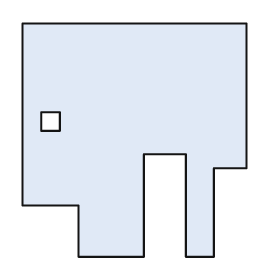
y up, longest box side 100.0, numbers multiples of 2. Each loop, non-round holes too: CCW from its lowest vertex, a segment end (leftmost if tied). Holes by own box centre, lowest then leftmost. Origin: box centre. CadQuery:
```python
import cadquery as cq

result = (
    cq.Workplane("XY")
    .moveTo(-24.0, -50.0)
    .lineTo(4.0, -50.0)
    .lineTo(4.0, -6.0)
    .lineTo(22.0, -6.0)
    .lineTo(22.0, -50.0)
    .lineTo(34.0, -50.0)
    .lineTo(34.0, -12.0)
    .lineTo(48.0, -12.0)
    .lineTo(48.0, 50.0)
    .lineTo(-48.0, 50.0)
    .lineTo(-48.0, -28.0)
    .lineTo(-24.0, -28.0)
    .close()
    .moveTo(-40.0, 4.0)
    .lineTo(-32.0, 4.0)
    .lineTo(-32.0, 12.0)
    .lineTo(-40.0, 12.0)
    .close()
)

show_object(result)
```